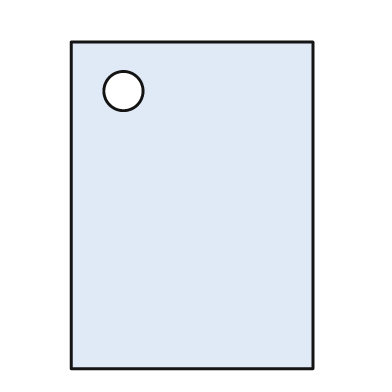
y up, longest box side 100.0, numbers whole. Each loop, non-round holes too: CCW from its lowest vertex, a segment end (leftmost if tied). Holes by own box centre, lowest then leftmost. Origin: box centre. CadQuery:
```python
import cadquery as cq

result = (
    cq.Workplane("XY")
    .moveTo(-37.0, -50.0)
    .lineTo(37.0, -50.0)
    .lineTo(37.0, 50.0)
    .lineTo(-37.0, 50.0)
    .close()
    .moveTo(-21.0, 35.0)
    .circle(6.0)
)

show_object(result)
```